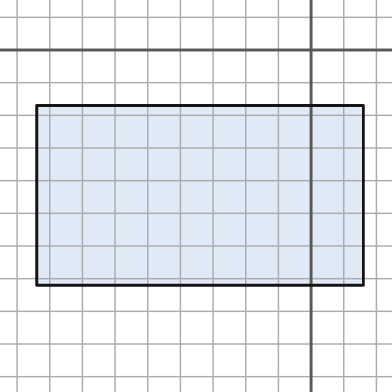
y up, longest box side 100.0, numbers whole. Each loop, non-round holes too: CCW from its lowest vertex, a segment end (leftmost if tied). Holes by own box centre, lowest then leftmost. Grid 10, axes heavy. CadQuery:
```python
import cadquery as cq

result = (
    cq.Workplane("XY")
    .moveTo(-84.0, -72.0)
    .lineTo(16.0, -72.0)
    .lineTo(16.0, -17.0)
    .lineTo(-84.0, -17.0)
    .close()
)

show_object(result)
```